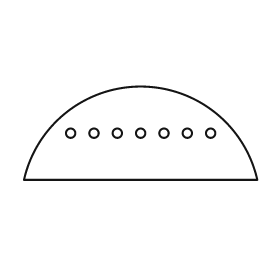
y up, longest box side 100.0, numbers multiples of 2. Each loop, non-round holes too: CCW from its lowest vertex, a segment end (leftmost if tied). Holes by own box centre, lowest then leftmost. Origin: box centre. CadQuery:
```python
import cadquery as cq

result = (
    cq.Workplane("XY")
    .moveTo(-50.0, -20.0)
    .lineTo(50.0, -20.0)
    .threePointArc((0.0, 20.0), (-50.0, -20.0))
    .close()
    .moveTo(-30.0, 0.0)
    .circle(2.0)
    .moveTo(-20.0, 0.0)
    .circle(2.0)
    .moveTo(-10.0, 0.0)
    .circle(2.0)
    .moveTo(0.0, 0.0)
    .circle(2.0)
    .moveTo(10.0, 0.0)
    .circle(2.0)
    .moveTo(20.0, 0.0)
    .circle(2.0)
    .moveTo(30.0, 0.0)
    .circle(2.0)
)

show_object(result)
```